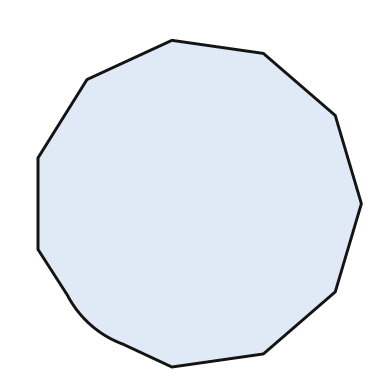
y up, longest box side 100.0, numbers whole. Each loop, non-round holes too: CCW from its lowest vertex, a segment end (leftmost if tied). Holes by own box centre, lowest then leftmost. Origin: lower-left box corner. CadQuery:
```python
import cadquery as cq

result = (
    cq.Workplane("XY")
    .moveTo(41.0, 0.0)
    .lineTo(69.0, 4.0)
    .lineTo(91.0, 23.0)
    .lineTo(99.0, 50.0)
    .lineTo(91.0, 77.0)
    .lineTo(69.0, 96.0)
    .lineTo(41.0, 100.0)
    .lineTo(15.0, 88.0)
    .lineTo(0.0, 64.0)
    .lineTo(0.0, 36.0)
    .lineTo(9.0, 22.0)
    .threePointArc((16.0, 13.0), (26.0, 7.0))
    .close()
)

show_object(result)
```